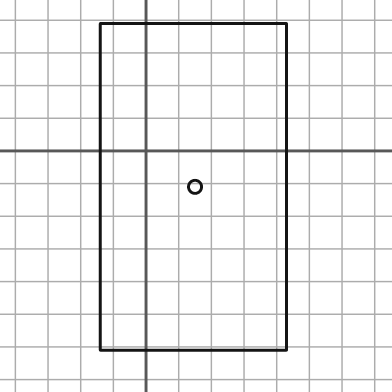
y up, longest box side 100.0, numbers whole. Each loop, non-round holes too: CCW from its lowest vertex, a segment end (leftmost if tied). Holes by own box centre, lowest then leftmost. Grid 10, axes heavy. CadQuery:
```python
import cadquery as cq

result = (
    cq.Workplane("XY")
    .moveTo(-14.0, -61.0)
    .lineTo(43.0, -61.0)
    .lineTo(43.0, 39.0)
    .lineTo(-14.0, 39.0)
    .close()
    .moveTo(15.0, -11.0)
    .circle(2.0)
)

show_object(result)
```